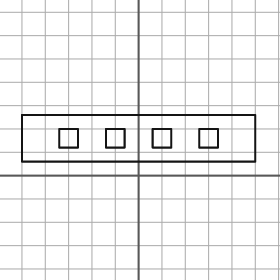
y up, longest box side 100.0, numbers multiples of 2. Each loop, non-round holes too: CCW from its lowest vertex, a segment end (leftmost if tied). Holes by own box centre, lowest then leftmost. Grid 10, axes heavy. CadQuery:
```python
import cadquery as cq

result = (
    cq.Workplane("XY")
    .moveTo(-50.0, 6.0)
    .lineTo(50.0, 6.0)
    .lineTo(50.0, 26.0)
    .lineTo(-50.0, 26.0)
    .close()
    .moveTo(-34.0, 12.0)
    .lineTo(-26.0, 12.0)
    .lineTo(-26.0, 20.0)
    .lineTo(-34.0, 20.0)
    .close()
    .moveTo(-14.0, 12.0)
    .lineTo(-6.0, 12.0)
    .lineTo(-6.0, 20.0)
    .lineTo(-14.0, 20.0)
    .close()
    .moveTo(6.0, 12.0)
    .lineTo(14.0, 12.0)
    .lineTo(14.0, 20.0)
    .lineTo(6.0, 20.0)
    .close()
    .moveTo(26.0, 12.0)
    .lineTo(34.0, 12.0)
    .lineTo(34.0, 20.0)
    .lineTo(26.0, 20.0)
    .close()
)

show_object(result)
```